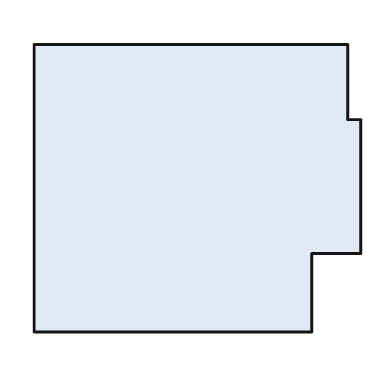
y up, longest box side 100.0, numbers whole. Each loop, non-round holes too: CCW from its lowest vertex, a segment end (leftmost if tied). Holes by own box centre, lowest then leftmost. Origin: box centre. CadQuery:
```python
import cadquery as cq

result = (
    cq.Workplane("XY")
    .moveTo(-50.0, -44.0)
    .lineTo(35.0, -44.0)
    .lineTo(35.0, -20.0)
    .lineTo(50.0, -20.0)
    .lineTo(50.0, 21.0)
    .lineTo(46.0, 21.0)
    .lineTo(46.0, 44.0)
    .lineTo(-50.0, 44.0)
    .close()
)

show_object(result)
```